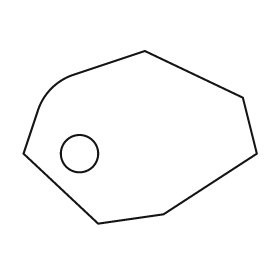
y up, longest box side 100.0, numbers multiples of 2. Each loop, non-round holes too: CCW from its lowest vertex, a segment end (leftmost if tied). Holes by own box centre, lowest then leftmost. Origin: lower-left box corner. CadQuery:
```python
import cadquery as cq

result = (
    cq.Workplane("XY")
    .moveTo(32.0, 0.0)
    .lineTo(60.0, 4.0)
    .lineTo(100.0, 30.0)
    .lineTo(94.0, 54.0)
    .lineTo(52.0, 74.0)
    .lineTo(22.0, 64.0)
    .threePointArc((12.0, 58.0), (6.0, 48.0))
    .lineTo(0.0, 30.0)
    .close()
    .moveTo(24.0, 30.0)
    .circle(8.0)
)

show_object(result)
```